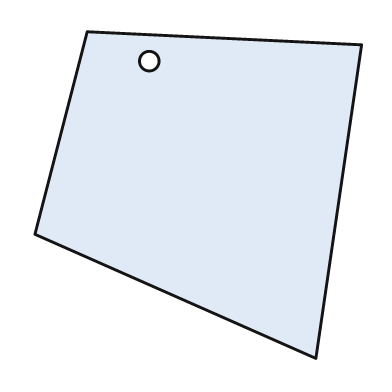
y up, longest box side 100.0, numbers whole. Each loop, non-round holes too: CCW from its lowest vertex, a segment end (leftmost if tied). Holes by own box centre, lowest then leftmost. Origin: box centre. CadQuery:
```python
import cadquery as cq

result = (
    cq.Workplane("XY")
    .moveTo(36.0, -50.0)
    .lineTo(50.0, 46.0)
    .lineTo(-34.0, 50.0)
    .lineTo(-50.0, -12.0)
    .close()
    .moveTo(-15.0, 41.0)
    .circle(3.0)
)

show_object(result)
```